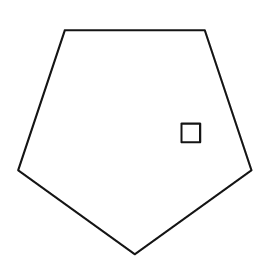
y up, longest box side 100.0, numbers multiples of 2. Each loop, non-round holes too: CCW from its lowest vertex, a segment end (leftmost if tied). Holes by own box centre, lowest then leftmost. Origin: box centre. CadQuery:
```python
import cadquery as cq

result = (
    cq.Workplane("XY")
    .moveTo(0.0, -48.0)
    .lineTo(50.0, -12.0)
    .lineTo(30.0, 48.0)
    .lineTo(-30.0, 48.0)
    .lineTo(-50.0, -12.0)
    .close()
    .moveTo(20.0, 0.0)
    .lineTo(28.0, 0.0)
    .lineTo(28.0, 8.0)
    .lineTo(20.0, 8.0)
    .close()
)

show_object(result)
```